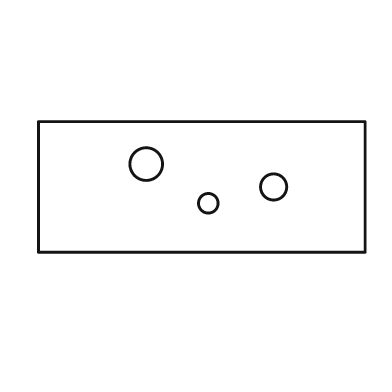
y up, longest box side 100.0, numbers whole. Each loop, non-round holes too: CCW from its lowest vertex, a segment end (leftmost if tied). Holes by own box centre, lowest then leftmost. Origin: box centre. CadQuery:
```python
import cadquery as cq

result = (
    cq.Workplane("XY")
    .moveTo(-50.0, -20.0)
    .lineTo(50.0, -20.0)
    .lineTo(50.0, 20.0)
    .lineTo(-50.0, 20.0)
    .close()
    .moveTo(2.0, -5.0)
    .circle(3.0)
    .moveTo(22.0, 0.0)
    .circle(4.0)
    .moveTo(-17.0, 7.0)
    .circle(5.0)
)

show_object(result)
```